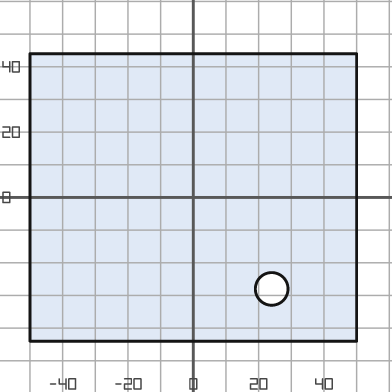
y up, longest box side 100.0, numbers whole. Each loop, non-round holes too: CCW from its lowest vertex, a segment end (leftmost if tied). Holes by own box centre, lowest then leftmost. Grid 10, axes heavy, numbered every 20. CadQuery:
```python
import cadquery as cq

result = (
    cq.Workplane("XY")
    .moveTo(-50.0, -44.0)
    .lineTo(50.0, -44.0)
    .lineTo(50.0, 44.0)
    .lineTo(-50.0, 44.0)
    .close()
    .moveTo(24.0, -28.0)
    .circle(5.0)
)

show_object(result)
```